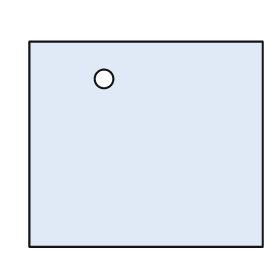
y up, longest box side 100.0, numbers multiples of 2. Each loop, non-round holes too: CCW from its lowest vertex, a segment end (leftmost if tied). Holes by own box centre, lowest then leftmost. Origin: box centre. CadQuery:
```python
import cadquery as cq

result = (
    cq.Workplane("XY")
    .moveTo(-50.0, -44.0)
    .lineTo(50.0, -44.0)
    .lineTo(50.0, 44.0)
    .lineTo(-50.0, 44.0)
    .close()
    .moveTo(-18.0, 28.0)
    .circle(4.0)
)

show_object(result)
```